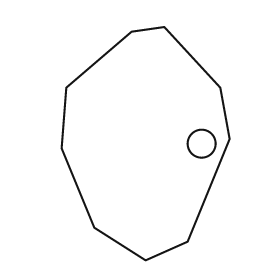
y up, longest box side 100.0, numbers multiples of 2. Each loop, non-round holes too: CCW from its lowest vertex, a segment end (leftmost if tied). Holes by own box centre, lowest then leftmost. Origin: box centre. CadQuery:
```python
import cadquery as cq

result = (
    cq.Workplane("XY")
    .moveTo(0.0, -50.0)
    .lineTo(18.0, -42.0)
    .lineTo(36.0, 2.0)
    .lineTo(32.0, 24.0)
    .lineTo(8.0, 50.0)
    .lineTo(-6.0, 48.0)
    .lineTo(-34.0, 24.0)
    .lineTo(-36.0, -2.0)
    .lineTo(-22.0, -36.0)
    .close()
    .moveTo(24.0, 0.0)
    .circle(6.0)
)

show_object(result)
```